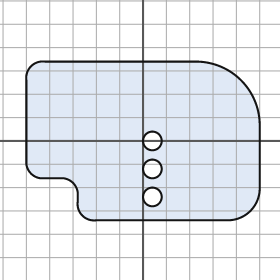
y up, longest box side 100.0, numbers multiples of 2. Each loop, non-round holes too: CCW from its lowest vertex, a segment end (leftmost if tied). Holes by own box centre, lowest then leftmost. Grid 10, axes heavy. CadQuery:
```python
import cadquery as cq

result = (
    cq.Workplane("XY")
    .moveTo(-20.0, -34.0)
    .lineTo(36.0, -34.0)
    .threePointArc((46.0, -30.0), (50.0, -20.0))
    .lineTo(50.0, 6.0)
    .threePointArc((42.0, 26.0), (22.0, 34.0))
    .lineTo(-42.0, 34.0)
    .threePointArc((-48.0, 32.0), (-50.0, 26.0))
    .lineTo(-50.0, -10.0)
    .threePointArc((-48.0, -14.0), (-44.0, -16.0))
    .lineTo(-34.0, -16.0)
    .threePointArc((-30.0, -18.0), (-28.0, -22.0))
    .lineTo(-28.0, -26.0)
    .threePointArc((-26.0, -32.0), (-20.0, -34.0))
    .close()
    .moveTo(4.0, -24.0)
    .circle(4.0)
    .moveTo(4.0, -12.0)
    .circle(4.0)
    .moveTo(4.0, 0.0)
    .circle(4.0)
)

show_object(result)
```